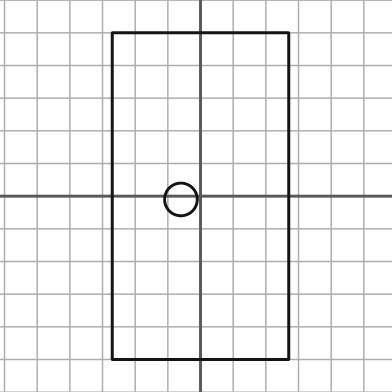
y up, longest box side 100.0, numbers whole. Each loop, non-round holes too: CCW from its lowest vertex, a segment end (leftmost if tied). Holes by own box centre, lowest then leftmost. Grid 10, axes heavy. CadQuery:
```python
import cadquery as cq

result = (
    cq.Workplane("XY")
    .moveTo(-27.0, -50.0)
    .lineTo(27.0, -50.0)
    .lineTo(27.0, 50.0)
    .lineTo(-27.0, 50.0)
    .close()
    .moveTo(-6.0, -1.0)
    .circle(5.0)
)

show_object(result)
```